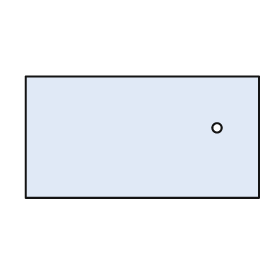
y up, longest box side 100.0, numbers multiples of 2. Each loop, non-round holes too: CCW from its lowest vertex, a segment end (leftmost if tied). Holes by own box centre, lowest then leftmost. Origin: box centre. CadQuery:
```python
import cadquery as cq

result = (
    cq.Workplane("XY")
    .moveTo(-50.0, -26.0)
    .lineTo(50.0, -26.0)
    .lineTo(50.0, 26.0)
    .lineTo(-50.0, 26.0)
    .close()
    .moveTo(32.0, 4.0)
    .circle(2.0)
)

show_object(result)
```